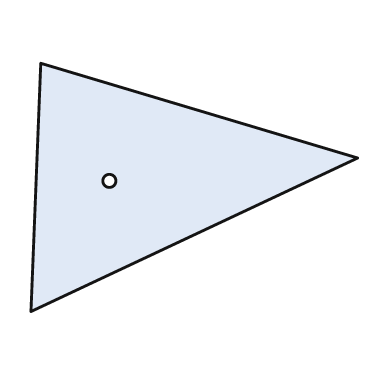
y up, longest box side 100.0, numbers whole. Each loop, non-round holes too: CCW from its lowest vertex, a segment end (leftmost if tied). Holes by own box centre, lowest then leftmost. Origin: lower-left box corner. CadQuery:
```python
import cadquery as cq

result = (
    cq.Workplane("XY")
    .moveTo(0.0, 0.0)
    .lineTo(100.0, 47.0)
    .lineTo(3.0, 76.0)
    .close()
    .moveTo(24.0, 40.0)
    .circle(2.0)
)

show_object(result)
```